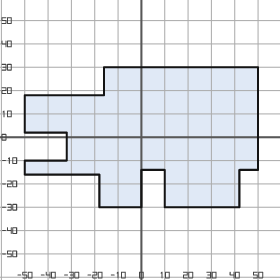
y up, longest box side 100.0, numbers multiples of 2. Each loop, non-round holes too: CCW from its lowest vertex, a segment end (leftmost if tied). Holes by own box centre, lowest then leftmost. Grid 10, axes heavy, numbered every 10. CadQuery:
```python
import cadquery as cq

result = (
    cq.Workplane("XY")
    .moveTo(-18.0, -30.0)
    .lineTo(0.0, -30.0)
    .lineTo(0.0, -14.0)
    .lineTo(10.0, -14.0)
    .lineTo(10.0, -30.0)
    .lineTo(42.0, -30.0)
    .lineTo(42.0, -14.0)
    .lineTo(50.0, -14.0)
    .lineTo(50.0, 30.0)
    .lineTo(-16.0, 30.0)
    .lineTo(-16.0, 18.0)
    .lineTo(-50.0, 18.0)
    .lineTo(-50.0, 2.0)
    .lineTo(-32.0, 2.0)
    .lineTo(-32.0, -10.0)
    .lineTo(-50.0, -10.0)
    .lineTo(-50.0, -16.0)
    .lineTo(-18.0, -16.0)
    .close()
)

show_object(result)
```